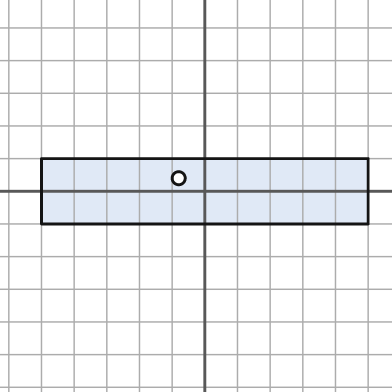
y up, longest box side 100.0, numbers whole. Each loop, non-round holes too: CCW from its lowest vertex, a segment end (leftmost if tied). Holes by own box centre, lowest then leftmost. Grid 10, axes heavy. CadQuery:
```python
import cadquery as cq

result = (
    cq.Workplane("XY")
    .moveTo(-50.0, -10.0)
    .lineTo(50.0, -10.0)
    .lineTo(50.0, 10.0)
    .lineTo(-50.0, 10.0)
    .close()
    .moveTo(-8.0, 4.0)
    .circle(2.0)
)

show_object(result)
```